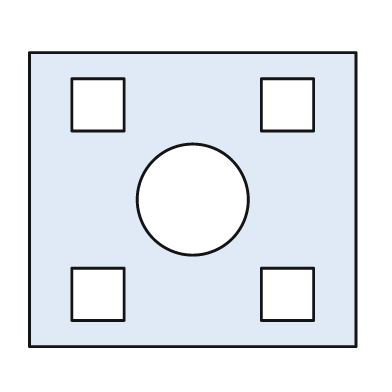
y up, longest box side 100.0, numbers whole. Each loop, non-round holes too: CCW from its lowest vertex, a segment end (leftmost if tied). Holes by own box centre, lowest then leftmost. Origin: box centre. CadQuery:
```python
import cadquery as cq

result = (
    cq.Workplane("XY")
    .moveTo(-50.0, -45.0)
    .lineTo(50.0, -45.0)
    .lineTo(50.0, 45.0)
    .lineTo(-50.0, 45.0)
    .close()
    .moveTo(-37.0, -37.0)
    .lineTo(-21.0, -37.0)
    .lineTo(-21.0, -21.0)
    .lineTo(-37.0, -21.0)
    .close()
    .moveTo(21.0, -37.0)
    .lineTo(37.0, -37.0)
    .lineTo(37.0, -21.0)
    .lineTo(21.0, -21.0)
    .close()
    .moveTo(0.0, 0.0)
    .circle(17.0)
    .moveTo(-37.0, 21.0)
    .lineTo(-21.0, 21.0)
    .lineTo(-21.0, 37.0)
    .lineTo(-37.0, 37.0)
    .close()
    .moveTo(21.0, 21.0)
    .lineTo(37.0, 21.0)
    .lineTo(37.0, 37.0)
    .lineTo(21.0, 37.0)
    .close()
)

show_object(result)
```